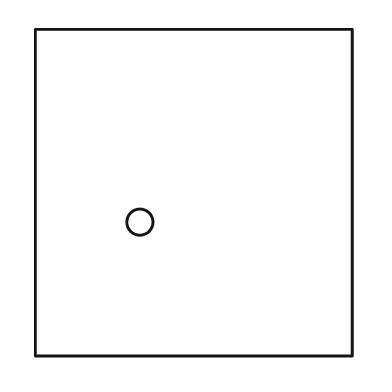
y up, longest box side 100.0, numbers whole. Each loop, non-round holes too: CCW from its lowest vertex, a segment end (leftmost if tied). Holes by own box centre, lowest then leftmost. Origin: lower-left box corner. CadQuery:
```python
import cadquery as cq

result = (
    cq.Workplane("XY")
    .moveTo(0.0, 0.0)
    .lineTo(97.0, 0.0)
    .lineTo(97.0, 100.0)
    .lineTo(0.0, 100.0)
    .close()
    .moveTo(32.0, 41.0)
    .circle(4.0)
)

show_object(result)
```